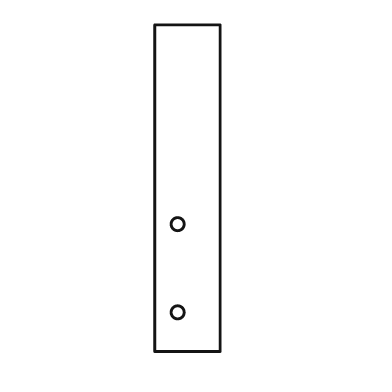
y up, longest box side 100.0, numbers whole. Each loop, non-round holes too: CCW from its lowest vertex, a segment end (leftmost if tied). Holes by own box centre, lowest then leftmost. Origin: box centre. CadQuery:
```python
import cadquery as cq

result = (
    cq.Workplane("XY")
    .moveTo(-10.0, -50.0)
    .lineTo(10.0, -50.0)
    .lineTo(10.0, 50.0)
    .lineTo(-10.0, 50.0)
    .close()
    .moveTo(-3.0, -38.0)
    .circle(2.0)
    .moveTo(-3.0, -11.0)
    .circle(2.0)
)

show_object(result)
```